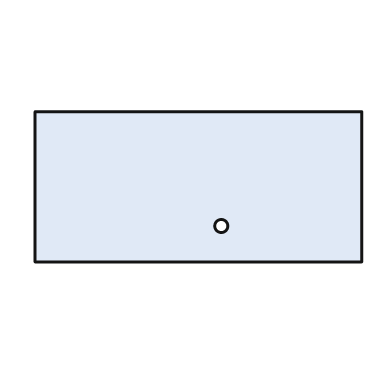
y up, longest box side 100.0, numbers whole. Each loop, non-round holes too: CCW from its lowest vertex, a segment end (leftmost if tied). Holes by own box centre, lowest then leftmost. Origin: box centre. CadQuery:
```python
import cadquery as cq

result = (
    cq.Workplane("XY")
    .moveTo(-50.0, -23.0)
    .lineTo(50.0, -23.0)
    .lineTo(50.0, 23.0)
    .lineTo(-50.0, 23.0)
    .close()
    .moveTo(7.0, -12.0)
    .circle(2.0)
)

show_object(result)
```